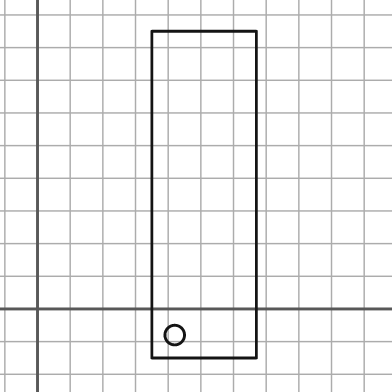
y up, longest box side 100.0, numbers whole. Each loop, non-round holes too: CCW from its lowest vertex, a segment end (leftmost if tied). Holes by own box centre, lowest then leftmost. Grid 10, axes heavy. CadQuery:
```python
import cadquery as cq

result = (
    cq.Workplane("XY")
    .moveTo(35.0, -15.0)
    .lineTo(67.0, -15.0)
    .lineTo(67.0, 85.0)
    .lineTo(35.0, 85.0)
    .close()
    .moveTo(42.0, -8.0)
    .circle(3.0)
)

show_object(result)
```